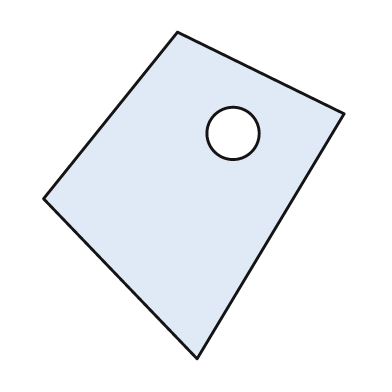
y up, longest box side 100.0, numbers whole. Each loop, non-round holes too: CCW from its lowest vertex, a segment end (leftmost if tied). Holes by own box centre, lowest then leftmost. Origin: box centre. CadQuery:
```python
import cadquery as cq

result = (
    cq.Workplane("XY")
    .moveTo(1.0, -50.0)
    .lineTo(46.0, 25.0)
    .lineTo(-5.0, 50.0)
    .lineTo(-46.0, -1.0)
    .close()
    .moveTo(12.0, 19.0)
    .circle(8.0)
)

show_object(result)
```